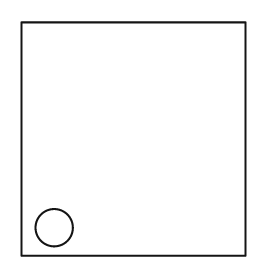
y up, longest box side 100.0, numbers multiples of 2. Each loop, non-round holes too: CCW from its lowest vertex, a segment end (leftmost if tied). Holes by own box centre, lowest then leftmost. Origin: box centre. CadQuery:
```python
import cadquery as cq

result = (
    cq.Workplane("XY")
    .moveTo(-48.0, -50.0)
    .lineTo(48.0, -50.0)
    .lineTo(48.0, 50.0)
    .lineTo(-48.0, 50.0)
    .close()
    .moveTo(-34.0, -38.0)
    .circle(8.0)
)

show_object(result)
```